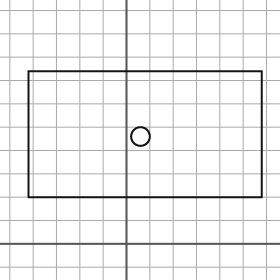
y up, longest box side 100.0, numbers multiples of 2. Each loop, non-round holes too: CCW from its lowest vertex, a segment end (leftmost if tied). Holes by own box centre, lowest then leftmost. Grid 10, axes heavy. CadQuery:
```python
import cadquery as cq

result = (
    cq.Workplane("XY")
    .moveTo(-42.0, 20.0)
    .lineTo(58.0, 20.0)
    .lineTo(58.0, 74.0)
    .lineTo(-42.0, 74.0)
    .close()
    .moveTo(6.0, 46.0)
    .circle(4.0)
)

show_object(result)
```